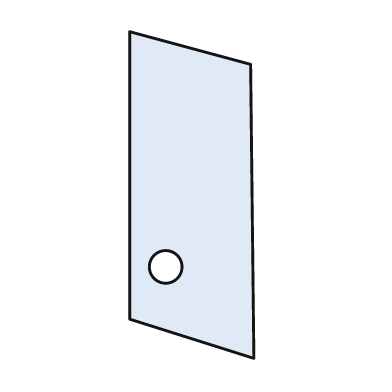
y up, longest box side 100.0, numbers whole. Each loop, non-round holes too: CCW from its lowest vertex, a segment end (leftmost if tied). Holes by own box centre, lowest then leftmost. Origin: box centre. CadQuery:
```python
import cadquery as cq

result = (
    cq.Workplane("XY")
    .moveTo(19.0, -50.0)
    .lineTo(18.0, 40.0)
    .lineTo(-19.0, 50.0)
    .lineTo(-19.0, -38.0)
    .close()
    .moveTo(-8.0, -22.0)
    .circle(5.0)
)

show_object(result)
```